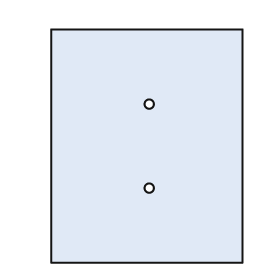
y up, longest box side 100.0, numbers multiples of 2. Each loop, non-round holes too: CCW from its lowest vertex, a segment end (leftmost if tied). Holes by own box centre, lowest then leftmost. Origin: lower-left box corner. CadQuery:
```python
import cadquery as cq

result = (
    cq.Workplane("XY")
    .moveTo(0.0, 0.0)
    .lineTo(82.0, 0.0)
    .lineTo(82.0, 100.0)
    .lineTo(0.0, 100.0)
    .close()
    .moveTo(42.0, 32.0)
    .circle(2.0)
    .moveTo(42.0, 68.0)
    .circle(2.0)
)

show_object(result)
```